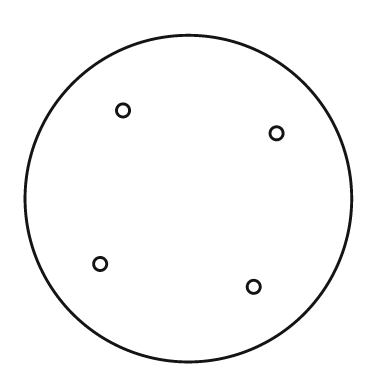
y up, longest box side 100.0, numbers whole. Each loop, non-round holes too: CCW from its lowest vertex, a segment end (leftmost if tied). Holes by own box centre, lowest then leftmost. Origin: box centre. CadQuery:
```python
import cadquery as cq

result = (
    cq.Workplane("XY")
    .moveTo(0.0, 0.0)
    .circle(50.0)
    .moveTo(20.0, -27.0)
    .circle(2.0)
    .moveTo(-27.0, -20.0)
    .circle(2.0)
    .moveTo(27.0, 20.0)
    .circle(2.0)
    .moveTo(-20.0, 27.0)
    .circle(2.0)
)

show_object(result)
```